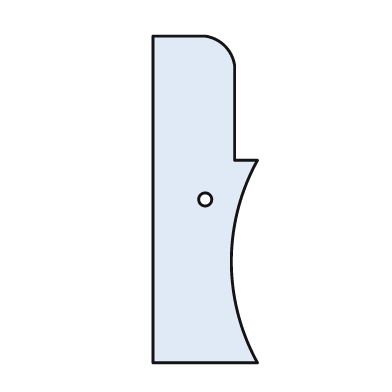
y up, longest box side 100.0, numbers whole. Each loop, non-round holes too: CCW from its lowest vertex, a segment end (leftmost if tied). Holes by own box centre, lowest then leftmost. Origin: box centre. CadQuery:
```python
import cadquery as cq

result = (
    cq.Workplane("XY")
    .moveTo(-16.0, -50.0)
    .lineTo(16.0, -50.0)
    .threePointArc((8.0, -19.0), (16.0, 12.0))
    .lineTo(9.0, 12.0)
    .lineTo(9.0, 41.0)
    .threePointArc((6.0, 47.0), (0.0, 50.0))
    .lineTo(-16.0, 50.0)
    .close()
    .moveTo(0.0, 0.0)
    .circle(2.0)
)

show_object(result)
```